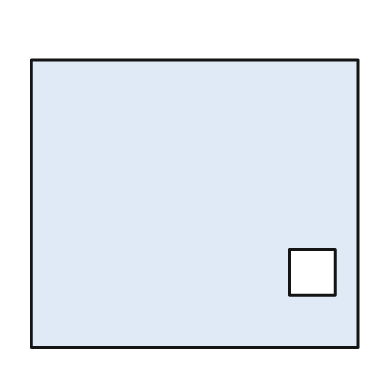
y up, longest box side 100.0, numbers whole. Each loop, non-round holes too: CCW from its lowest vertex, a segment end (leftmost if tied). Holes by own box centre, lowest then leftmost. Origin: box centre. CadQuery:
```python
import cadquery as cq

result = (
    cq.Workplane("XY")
    .moveTo(-50.0, -44.0)
    .lineTo(50.0, -44.0)
    .lineTo(50.0, 44.0)
    .lineTo(-50.0, 44.0)
    .close()
    .moveTo(29.0, -28.0)
    .lineTo(43.0, -28.0)
    .lineTo(43.0, -14.0)
    .lineTo(29.0, -14.0)
    .close()
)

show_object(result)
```